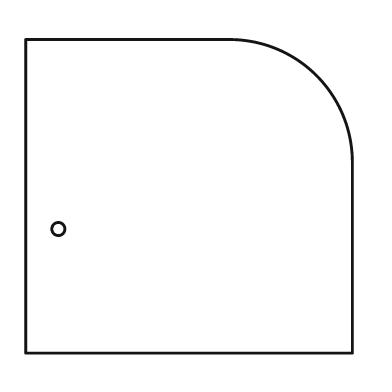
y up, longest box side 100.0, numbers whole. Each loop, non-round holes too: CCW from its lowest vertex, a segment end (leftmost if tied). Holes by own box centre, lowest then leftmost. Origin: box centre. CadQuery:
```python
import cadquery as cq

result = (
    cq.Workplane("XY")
    .moveTo(-50.0, -48.0)
    .lineTo(50.0, -48.0)
    .lineTo(50.0, 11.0)
    .threePointArc((39.0, 37.0), (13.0, 48.0))
    .lineTo(-50.0, 48.0)
    .close()
    .moveTo(-40.0, -10.0)
    .circle(2.0)
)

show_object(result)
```